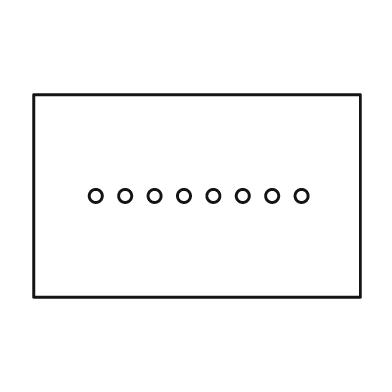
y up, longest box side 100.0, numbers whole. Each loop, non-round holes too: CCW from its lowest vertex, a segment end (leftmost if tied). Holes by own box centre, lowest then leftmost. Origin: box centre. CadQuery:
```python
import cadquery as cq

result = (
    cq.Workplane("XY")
    .moveTo(-50.0, -31.0)
    .lineTo(50.0, -31.0)
    .lineTo(50.0, 31.0)
    .lineTo(-50.0, 31.0)
    .close()
    .moveTo(-31.0, 0.0)
    .circle(2.0)
    .moveTo(-22.0, 0.0)
    .circle(2.0)
    .moveTo(-13.0, 0.0)
    .circle(2.0)
    .moveTo(-4.0, 0.0)
    .circle(2.0)
    .moveTo(5.0, 0.0)
    .circle(2.0)
    .moveTo(14.0, 0.0)
    .circle(2.0)
    .moveTo(23.0, 0.0)
    .circle(2.0)
    .moveTo(32.0, 0.0)
    .circle(2.0)
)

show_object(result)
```